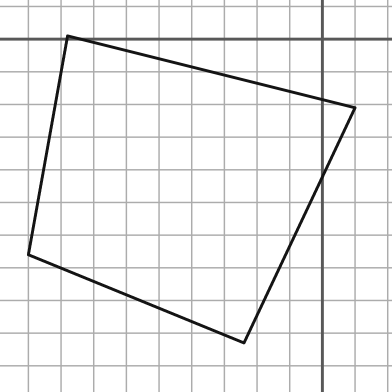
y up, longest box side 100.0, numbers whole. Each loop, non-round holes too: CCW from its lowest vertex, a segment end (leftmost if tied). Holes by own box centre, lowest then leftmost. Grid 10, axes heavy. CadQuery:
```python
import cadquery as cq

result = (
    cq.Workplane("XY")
    .moveTo(-24.0, -93.0)
    .lineTo(10.0, -21.0)
    .lineTo(-78.0, 1.0)
    .lineTo(-90.0, -66.0)
    .close()
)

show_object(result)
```